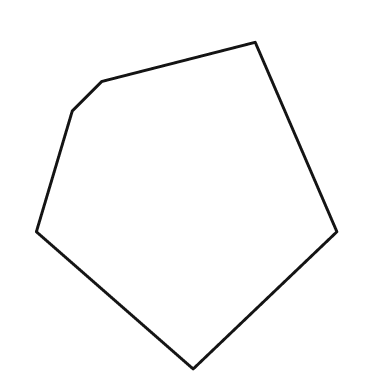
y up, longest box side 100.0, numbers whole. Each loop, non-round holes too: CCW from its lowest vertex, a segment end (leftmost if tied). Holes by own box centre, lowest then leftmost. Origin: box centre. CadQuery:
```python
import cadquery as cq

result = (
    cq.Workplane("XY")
    .moveTo(2.0, -50.0)
    .lineTo(46.0, -8.0)
    .lineTo(21.0, 50.0)
    .lineTo(-26.0, 38.0)
    .lineTo(-35.0, 29.0)
    .lineTo(-46.0, -8.0)
    .close()
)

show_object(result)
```